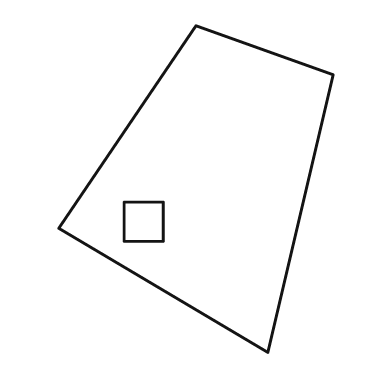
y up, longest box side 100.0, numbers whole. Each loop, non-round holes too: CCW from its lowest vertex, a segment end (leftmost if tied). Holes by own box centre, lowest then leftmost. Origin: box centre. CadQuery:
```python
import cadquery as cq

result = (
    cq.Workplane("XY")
    .moveTo(22.0, -50.0)
    .lineTo(42.0, 35.0)
    .lineTo(0.0, 50.0)
    .lineTo(-42.0, -12.0)
    .close()
    .moveTo(-22.0, -16.0)
    .lineTo(-10.0, -16.0)
    .lineTo(-10.0, -4.0)
    .lineTo(-22.0, -4.0)
    .close()
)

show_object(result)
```